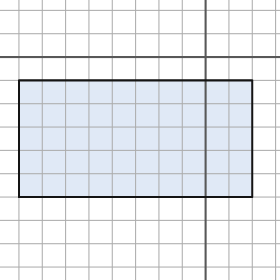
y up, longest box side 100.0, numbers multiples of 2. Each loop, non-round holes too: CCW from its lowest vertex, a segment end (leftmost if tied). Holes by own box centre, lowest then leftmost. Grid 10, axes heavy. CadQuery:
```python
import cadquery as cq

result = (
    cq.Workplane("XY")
    .moveTo(-80.0, -60.0)
    .lineTo(20.0, -60.0)
    .lineTo(20.0, -10.0)
    .lineTo(-80.0, -10.0)
    .close()
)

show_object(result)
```